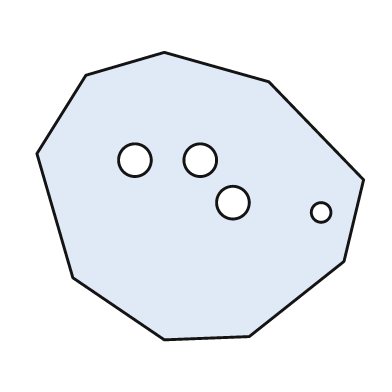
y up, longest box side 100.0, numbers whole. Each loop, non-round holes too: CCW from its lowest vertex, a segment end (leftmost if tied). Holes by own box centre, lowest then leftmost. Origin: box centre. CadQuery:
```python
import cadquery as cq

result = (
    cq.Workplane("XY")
    .moveTo(-11.0, -44.0)
    .lineTo(15.0, -43.0)
    .lineTo(44.0, -20.0)
    .lineTo(50.0, 5.0)
    .lineTo(21.0, 35.0)
    .lineTo(-11.0, 44.0)
    .lineTo(-35.0, 37.0)
    .lineTo(-50.0, 13.0)
    .lineTo(-39.0, -25.0)
    .close()
    .moveTo(37.0, -5.0)
    .circle(3.0)
    .moveTo(10.0, -2.0)
    .circle(5.0)
    .moveTo(-20.0, 11.0)
    .circle(5.0)
    .moveTo(0.0, 11.0)
    .circle(5.0)
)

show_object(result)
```